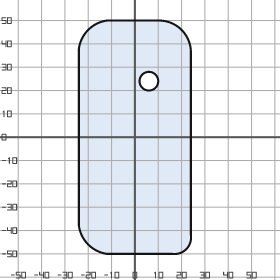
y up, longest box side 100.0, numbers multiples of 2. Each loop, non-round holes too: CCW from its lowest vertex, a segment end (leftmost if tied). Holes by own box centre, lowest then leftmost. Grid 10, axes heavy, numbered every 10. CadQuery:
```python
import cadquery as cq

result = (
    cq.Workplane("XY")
    .moveTo(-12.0, -50.0)
    .lineTo(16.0, -50.0)
    .threePointArc((22.0, -48.0), (24.0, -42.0))
    .lineTo(24.0, 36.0)
    .threePointArc((20.0, 46.0), (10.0, 50.0))
    .lineTo(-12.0, 50.0)
    .threePointArc((-20.0, 46.0), (-24.0, 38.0))
    .lineTo(-24.0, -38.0)
    .threePointArc((-20.0, -46.0), (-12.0, -50.0))
    .close()
    .moveTo(6.0, 24.0)
    .circle(4.0)
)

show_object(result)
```